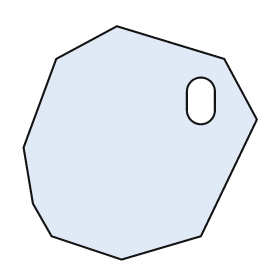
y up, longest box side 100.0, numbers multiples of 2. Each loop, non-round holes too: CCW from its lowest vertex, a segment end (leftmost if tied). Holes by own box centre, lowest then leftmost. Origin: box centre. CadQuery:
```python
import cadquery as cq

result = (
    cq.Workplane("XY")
    .moveTo(-8.0, -50.0)
    .lineTo(26.0, -40.0)
    .lineTo(50.0, 10.0)
    .lineTo(36.0, 36.0)
    .lineTo(-10.0, 50.0)
    .lineTo(-36.0, 36.0)
    .lineTo(-50.0, -2.0)
    .lineTo(-46.0, -26.0)
    .lineTo(-38.0, -40.0)
    .close()
    .moveTo(20.0, 14.0)
    .threePointArc((26.0, 8.0), (32.0, 14.0))
    .lineTo(32.0, 22.0)
    .threePointArc((26.0, 28.0), (20.0, 22.0))
    .close()
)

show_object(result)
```